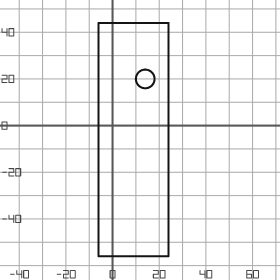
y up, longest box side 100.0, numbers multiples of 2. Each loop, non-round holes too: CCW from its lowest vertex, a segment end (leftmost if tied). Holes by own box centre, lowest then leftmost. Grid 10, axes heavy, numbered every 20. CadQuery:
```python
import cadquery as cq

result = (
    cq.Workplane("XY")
    .moveTo(-6.0, -56.0)
    .lineTo(24.0, -56.0)
    .lineTo(24.0, 44.0)
    .lineTo(-6.0, 44.0)
    .close()
    .moveTo(14.0, 20.0)
    .circle(4.0)
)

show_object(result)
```